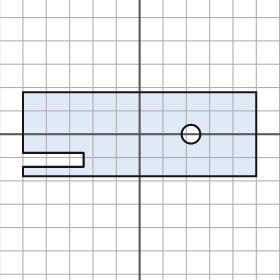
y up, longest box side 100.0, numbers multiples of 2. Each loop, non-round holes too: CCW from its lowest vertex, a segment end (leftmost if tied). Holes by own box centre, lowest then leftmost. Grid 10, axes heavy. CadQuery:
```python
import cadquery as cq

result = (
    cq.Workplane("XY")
    .moveTo(-50.0, -18.0)
    .lineTo(50.0, -18.0)
    .lineTo(50.0, 18.0)
    .lineTo(-50.0, 18.0)
    .lineTo(-50.0, -8.0)
    .lineTo(-24.0, -8.0)
    .lineTo(-24.0, -14.0)
    .lineTo(-50.0, -14.0)
    .close()
    .moveTo(22.0, 0.0)
    .circle(4.0)
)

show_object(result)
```